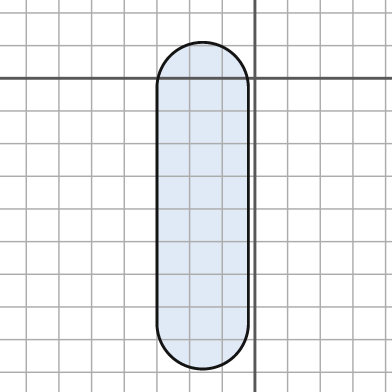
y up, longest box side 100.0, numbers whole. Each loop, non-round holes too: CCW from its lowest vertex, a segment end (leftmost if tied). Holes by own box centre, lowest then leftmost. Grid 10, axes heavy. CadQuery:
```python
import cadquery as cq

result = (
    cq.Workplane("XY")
    .moveTo(-30.0, -75.0)
    .threePointArc((-16.0, -89.0), (-2.0, -75.0))
    .lineTo(-2.0, -3.0)
    .threePointArc((-16.0, 11.0), (-30.0, -3.0))
    .close()
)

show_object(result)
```